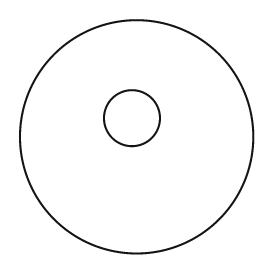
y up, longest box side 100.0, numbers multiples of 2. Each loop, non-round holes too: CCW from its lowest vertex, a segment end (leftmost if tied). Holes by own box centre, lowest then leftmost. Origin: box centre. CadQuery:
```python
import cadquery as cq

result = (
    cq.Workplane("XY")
    .moveTo(0.0, 0.0)
    .circle(50.0)
    .moveTo(-2.0, 8.0)
    .circle(12.0)
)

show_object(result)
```